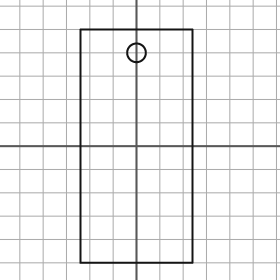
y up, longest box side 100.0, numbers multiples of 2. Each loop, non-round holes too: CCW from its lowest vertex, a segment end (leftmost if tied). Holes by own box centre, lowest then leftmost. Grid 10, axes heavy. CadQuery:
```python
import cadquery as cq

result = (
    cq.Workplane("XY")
    .moveTo(-24.0, -50.0)
    .lineTo(24.0, -50.0)
    .lineTo(24.0, 50.0)
    .lineTo(-24.0, 50.0)
    .close()
    .moveTo(0.0, 40.0)
    .circle(4.0)
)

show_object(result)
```